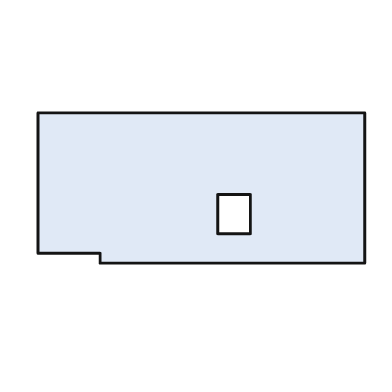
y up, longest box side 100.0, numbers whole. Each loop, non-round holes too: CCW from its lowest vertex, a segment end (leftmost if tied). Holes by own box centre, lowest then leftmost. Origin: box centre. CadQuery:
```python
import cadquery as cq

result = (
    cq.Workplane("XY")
    .moveTo(-31.0, -23.0)
    .lineTo(50.0, -23.0)
    .lineTo(50.0, 23.0)
    .lineTo(-50.0, 23.0)
    .lineTo(-50.0, -20.0)
    .lineTo(-31.0, -20.0)
    .close()
    .moveTo(5.0, -14.0)
    .lineTo(15.0, -14.0)
    .lineTo(15.0, -2.0)
    .lineTo(5.0, -2.0)
    .close()
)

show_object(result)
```